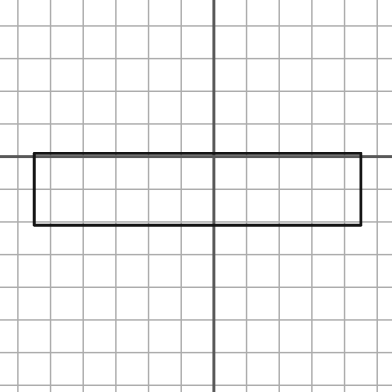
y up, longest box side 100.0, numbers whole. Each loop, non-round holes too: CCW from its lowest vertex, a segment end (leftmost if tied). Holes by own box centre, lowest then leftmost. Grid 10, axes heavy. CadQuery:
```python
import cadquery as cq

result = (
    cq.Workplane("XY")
    .moveTo(-55.0, -21.0)
    .lineTo(45.0, -21.0)
    .lineTo(45.0, 1.0)
    .lineTo(-55.0, 1.0)
    .close()
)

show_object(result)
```